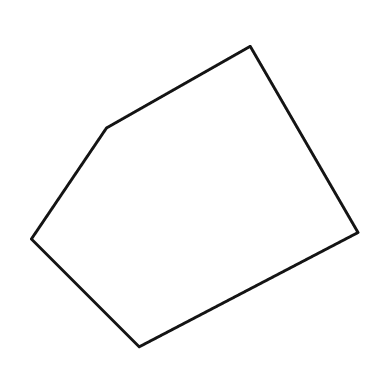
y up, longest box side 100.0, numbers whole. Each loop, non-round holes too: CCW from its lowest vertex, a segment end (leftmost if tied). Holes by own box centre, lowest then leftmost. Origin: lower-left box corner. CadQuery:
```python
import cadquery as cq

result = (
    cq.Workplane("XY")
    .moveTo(33.0, 0.0)
    .lineTo(100.0, 35.0)
    .lineTo(67.0, 92.0)
    .lineTo(23.0, 67.0)
    .lineTo(0.0, 33.0)
    .close()
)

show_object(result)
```